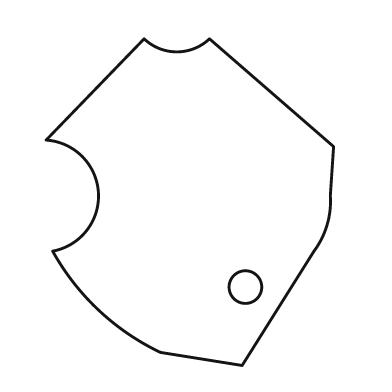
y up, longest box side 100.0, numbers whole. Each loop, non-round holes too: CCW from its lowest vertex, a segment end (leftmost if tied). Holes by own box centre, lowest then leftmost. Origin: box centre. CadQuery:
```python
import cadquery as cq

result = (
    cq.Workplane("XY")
    .moveTo(16.0, -50.0)
    .lineTo(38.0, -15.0)
    .threePointArc((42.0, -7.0), (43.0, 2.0))
    .lineTo(44.0, 17.0)
    .lineTo(6.0, 50.0)
    .threePointArc((-4.0, 46.0), (-14.0, 50.0))
    .lineTo(-44.0, 19.0)
    .threePointArc((-28.0, 3.0), (-42.0, -15.0))
    .threePointArc((-28.0, -33.0), (-9.0, -46.0))
    .close()
    .moveTo(17.0, -26.0)
    .circle(5.0)
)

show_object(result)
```